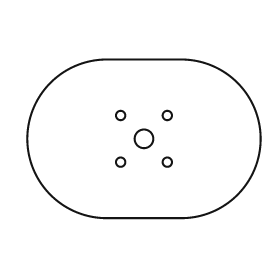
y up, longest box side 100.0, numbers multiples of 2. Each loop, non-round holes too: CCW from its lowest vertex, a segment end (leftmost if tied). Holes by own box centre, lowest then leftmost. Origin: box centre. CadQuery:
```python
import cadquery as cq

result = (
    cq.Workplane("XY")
    .moveTo(-16.0, -34.0)
    .lineTo(16.0, -34.0)
    .threePointArc((50.0, 0.0), (16.0, 34.0))
    .lineTo(-16.0, 34.0)
    .threePointArc((-50.0, 0.0), (-16.0, -34.0))
    .close()
    .moveTo(-10.0, -10.0)
    .circle(2.0)
    .moveTo(10.0, -10.0)
    .circle(2.0)
    .moveTo(0.0, 0.0)
    .circle(4.0)
    .moveTo(-10.0, 10.0)
    .circle(2.0)
    .moveTo(10.0, 10.0)
    .circle(2.0)
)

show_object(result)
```